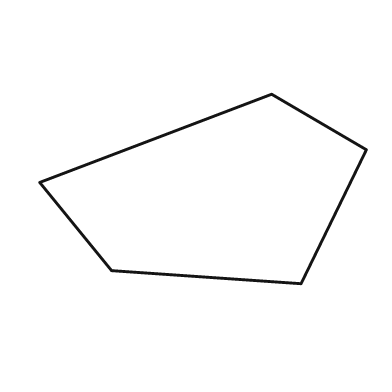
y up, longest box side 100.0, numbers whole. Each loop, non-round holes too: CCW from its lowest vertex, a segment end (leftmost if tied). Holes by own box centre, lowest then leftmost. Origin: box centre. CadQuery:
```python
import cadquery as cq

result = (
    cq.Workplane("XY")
    .moveTo(30.0, -29.0)
    .lineTo(50.0, 12.0)
    .lineTo(21.0, 29.0)
    .lineTo(-50.0, 2.0)
    .lineTo(-28.0, -25.0)
    .close()
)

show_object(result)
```